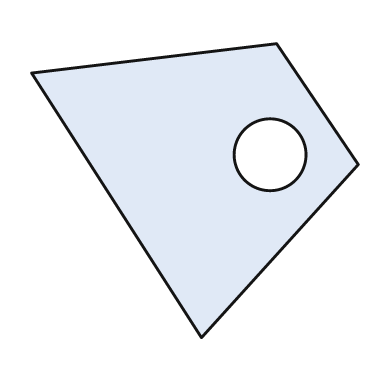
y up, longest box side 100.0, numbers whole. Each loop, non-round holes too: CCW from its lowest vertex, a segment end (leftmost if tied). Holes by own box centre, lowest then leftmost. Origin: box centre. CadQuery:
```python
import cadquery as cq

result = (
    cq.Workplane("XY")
    .moveTo(2.0, -45.0)
    .lineTo(50.0, 8.0)
    .lineTo(25.0, 45.0)
    .lineTo(-50.0, 36.0)
    .close()
    .moveTo(23.0, 11.0)
    .circle(11.0)
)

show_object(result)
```